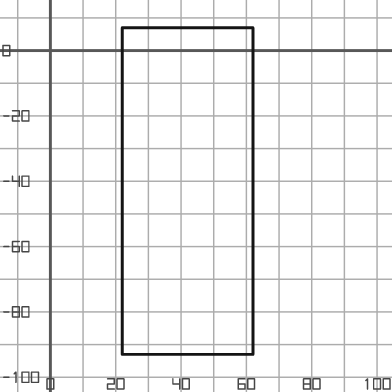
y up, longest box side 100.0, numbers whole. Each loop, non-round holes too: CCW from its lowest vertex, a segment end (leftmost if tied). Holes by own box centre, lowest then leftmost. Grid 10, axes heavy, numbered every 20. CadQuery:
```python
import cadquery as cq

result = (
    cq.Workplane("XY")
    .moveTo(22.0, -93.0)
    .lineTo(62.0, -93.0)
    .lineTo(62.0, 7.0)
    .lineTo(22.0, 7.0)
    .close()
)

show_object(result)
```